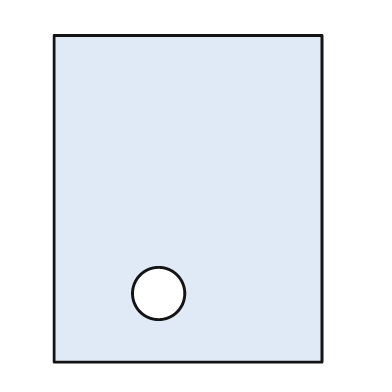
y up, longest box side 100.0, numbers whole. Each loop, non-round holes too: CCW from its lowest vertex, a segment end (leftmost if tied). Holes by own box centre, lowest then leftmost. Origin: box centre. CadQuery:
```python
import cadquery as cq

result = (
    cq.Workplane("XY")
    .moveTo(-41.0, -50.0)
    .lineTo(41.0, -50.0)
    .lineTo(41.0, 50.0)
    .lineTo(-41.0, 50.0)
    .close()
    .moveTo(-9.0, -29.0)
    .circle(8.0)
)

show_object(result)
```